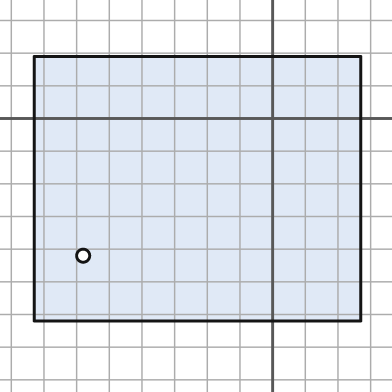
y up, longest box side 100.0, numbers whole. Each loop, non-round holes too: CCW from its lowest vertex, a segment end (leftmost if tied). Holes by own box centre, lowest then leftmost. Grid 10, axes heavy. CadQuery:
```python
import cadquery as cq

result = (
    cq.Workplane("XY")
    .moveTo(-73.0, -62.0)
    .lineTo(27.0, -62.0)
    .lineTo(27.0, 19.0)
    .lineTo(-73.0, 19.0)
    .close()
    .moveTo(-58.0, -42.0)
    .circle(2.0)
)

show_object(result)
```